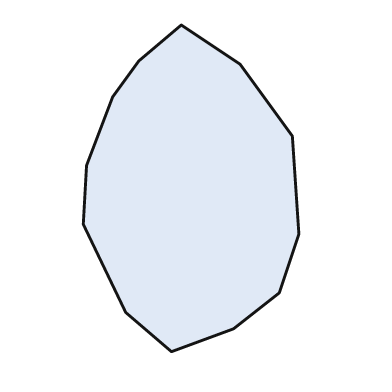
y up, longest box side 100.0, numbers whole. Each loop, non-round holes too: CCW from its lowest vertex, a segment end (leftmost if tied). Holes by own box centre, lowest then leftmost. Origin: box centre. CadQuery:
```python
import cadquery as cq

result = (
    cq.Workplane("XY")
    .moveTo(-6.0, -50.0)
    .lineTo(13.0, -43.0)
    .lineTo(27.0, -32.0)
    .lineTo(33.0, -14.0)
    .lineTo(31.0, 16.0)
    .lineTo(15.0, 38.0)
    .lineTo(-3.0, 50.0)
    .lineTo(-16.0, 39.0)
    .lineTo(-24.0, 28.0)
    .lineTo(-32.0, 7.0)
    .lineTo(-33.0, -11.0)
    .lineTo(-20.0, -38.0)
    .close()
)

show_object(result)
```